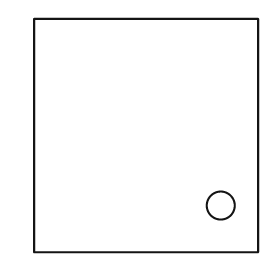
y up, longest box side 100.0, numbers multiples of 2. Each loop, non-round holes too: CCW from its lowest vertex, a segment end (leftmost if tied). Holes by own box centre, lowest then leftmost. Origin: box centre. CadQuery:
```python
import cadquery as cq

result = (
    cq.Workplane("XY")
    .moveTo(-48.0, -50.0)
    .lineTo(48.0, -50.0)
    .lineTo(48.0, 50.0)
    .lineTo(-48.0, 50.0)
    .close()
    .moveTo(32.0, -30.0)
    .circle(6.0)
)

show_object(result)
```